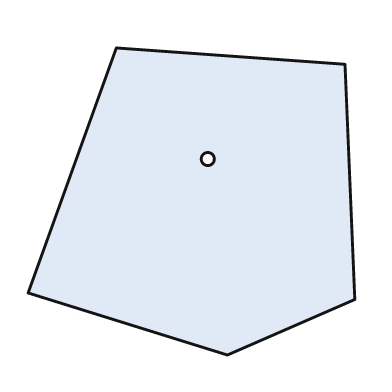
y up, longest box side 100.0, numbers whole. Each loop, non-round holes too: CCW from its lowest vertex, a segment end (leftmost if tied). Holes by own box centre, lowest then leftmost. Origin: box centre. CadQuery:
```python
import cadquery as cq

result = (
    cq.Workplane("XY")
    .moveTo(11.0, -47.0)
    .lineTo(50.0, -30.0)
    .lineTo(47.0, 42.0)
    .lineTo(-23.0, 47.0)
    .lineTo(-50.0, -28.0)
    .close()
    .moveTo(5.0, 13.0)
    .circle(2.0)
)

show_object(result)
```